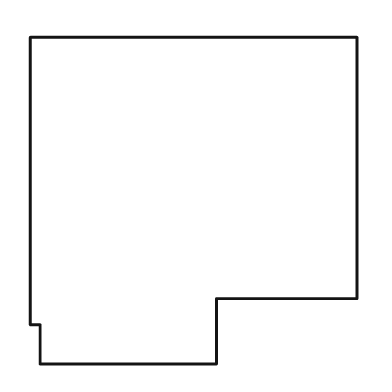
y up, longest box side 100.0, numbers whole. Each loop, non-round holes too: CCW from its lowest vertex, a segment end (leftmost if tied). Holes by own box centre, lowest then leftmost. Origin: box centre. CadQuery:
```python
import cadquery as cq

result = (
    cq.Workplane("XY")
    .moveTo(-47.0, -50.0)
    .lineTo(7.0, -50.0)
    .lineTo(7.0, -30.0)
    .lineTo(50.0, -30.0)
    .lineTo(50.0, 50.0)
    .lineTo(-50.0, 50.0)
    .lineTo(-50.0, -38.0)
    .lineTo(-47.0, -38.0)
    .close()
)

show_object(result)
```